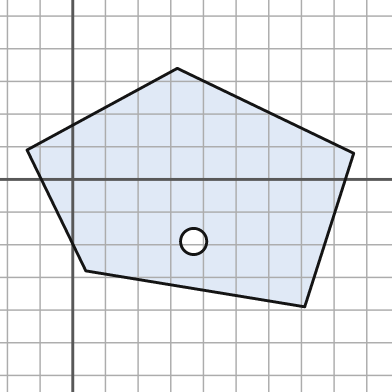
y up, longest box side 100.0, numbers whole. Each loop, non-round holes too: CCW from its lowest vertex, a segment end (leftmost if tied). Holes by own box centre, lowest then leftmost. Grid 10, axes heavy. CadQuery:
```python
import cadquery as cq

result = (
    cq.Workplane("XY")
    .moveTo(71.0, -39.0)
    .lineTo(86.0, 8.0)
    .lineTo(32.0, 34.0)
    .lineTo(-14.0, 9.0)
    .lineTo(4.0, -28.0)
    .close()
    .moveTo(37.0, -19.0)
    .circle(4.0)
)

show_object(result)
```